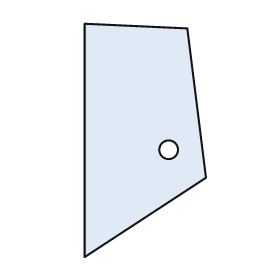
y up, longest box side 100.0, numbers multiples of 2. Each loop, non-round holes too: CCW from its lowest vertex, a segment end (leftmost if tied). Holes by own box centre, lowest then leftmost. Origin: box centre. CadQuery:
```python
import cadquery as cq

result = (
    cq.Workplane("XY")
    .moveTo(-26.0, -50.0)
    .lineTo(26.0, -16.0)
    .lineTo(18.0, 48.0)
    .lineTo(-26.0, 50.0)
    .close()
    .moveTo(10.0, -4.0)
    .circle(4.0)
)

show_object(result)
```